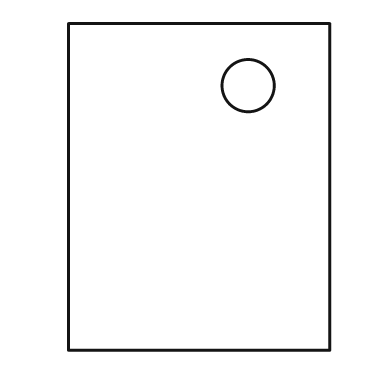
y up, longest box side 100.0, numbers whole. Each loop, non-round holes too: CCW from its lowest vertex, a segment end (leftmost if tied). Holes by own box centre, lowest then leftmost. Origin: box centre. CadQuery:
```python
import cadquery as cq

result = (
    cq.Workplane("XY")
    .moveTo(-40.0, -50.0)
    .lineTo(40.0, -50.0)
    .lineTo(40.0, 50.0)
    .lineTo(-40.0, 50.0)
    .close()
    .moveTo(15.0, 31.0)
    .circle(8.0)
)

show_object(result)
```